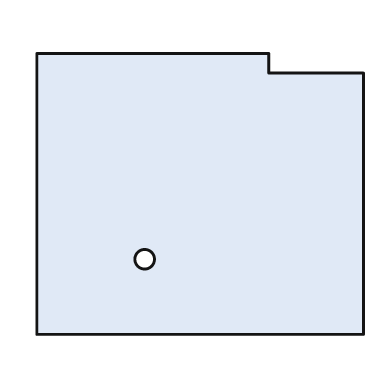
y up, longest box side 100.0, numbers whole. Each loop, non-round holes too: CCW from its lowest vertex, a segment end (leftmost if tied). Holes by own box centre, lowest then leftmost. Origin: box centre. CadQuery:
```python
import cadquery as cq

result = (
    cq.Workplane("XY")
    .moveTo(-50.0, -43.0)
    .lineTo(50.0, -43.0)
    .lineTo(50.0, 37.0)
    .lineTo(21.0, 37.0)
    .lineTo(21.0, 43.0)
    .lineTo(-50.0, 43.0)
    .close()
    .moveTo(-17.0, -20.0)
    .circle(3.0)
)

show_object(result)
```